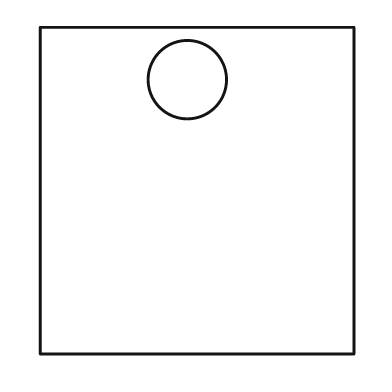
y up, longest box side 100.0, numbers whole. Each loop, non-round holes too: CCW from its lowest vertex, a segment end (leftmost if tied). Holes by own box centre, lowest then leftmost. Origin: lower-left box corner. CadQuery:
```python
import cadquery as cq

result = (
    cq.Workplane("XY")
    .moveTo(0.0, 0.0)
    .lineTo(96.0, 0.0)
    .lineTo(96.0, 100.0)
    .lineTo(0.0, 100.0)
    .close()
    .moveTo(45.0, 84.0)
    .circle(12.0)
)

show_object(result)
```